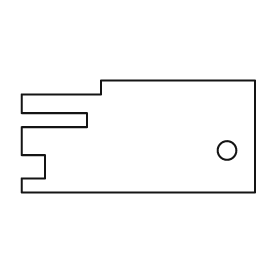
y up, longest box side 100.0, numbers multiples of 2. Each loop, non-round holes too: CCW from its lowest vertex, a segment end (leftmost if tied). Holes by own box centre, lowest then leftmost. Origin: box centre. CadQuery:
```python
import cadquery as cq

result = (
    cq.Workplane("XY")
    .moveTo(-50.0, -24.0)
    .lineTo(50.0, -24.0)
    .lineTo(50.0, 24.0)
    .lineTo(-16.0, 24.0)
    .lineTo(-16.0, 18.0)
    .lineTo(-50.0, 18.0)
    .lineTo(-50.0, 10.0)
    .lineTo(-22.0, 10.0)
    .lineTo(-22.0, 4.0)
    .lineTo(-50.0, 4.0)
    .lineTo(-50.0, -8.0)
    .lineTo(-40.0, -8.0)
    .lineTo(-40.0, -18.0)
    .lineTo(-50.0, -18.0)
    .close()
    .moveTo(38.0, -6.0)
    .circle(4.0)
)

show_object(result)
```